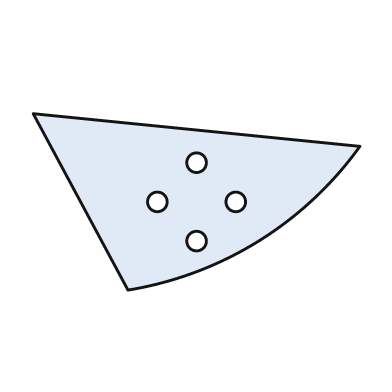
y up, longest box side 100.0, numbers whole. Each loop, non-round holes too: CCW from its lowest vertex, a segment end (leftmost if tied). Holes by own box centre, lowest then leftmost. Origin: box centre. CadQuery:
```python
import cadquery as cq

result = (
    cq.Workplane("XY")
    .moveTo(-21.0, -27.0)
    .threePointArc((19.0, -12.0), (50.0, 17.0))
    .lineTo(-50.0, 27.0)
    .close()
    .moveTo(0.0, -12.0)
    .circle(3.0)
    .moveTo(-12.0, 0.0)
    .circle(3.0)
    .moveTo(12.0, 0.0)
    .circle(3.0)
    .moveTo(0.0, 12.0)
    .circle(3.0)
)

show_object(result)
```